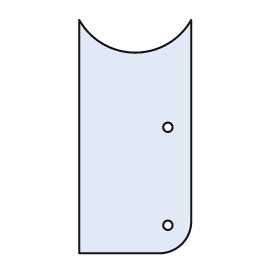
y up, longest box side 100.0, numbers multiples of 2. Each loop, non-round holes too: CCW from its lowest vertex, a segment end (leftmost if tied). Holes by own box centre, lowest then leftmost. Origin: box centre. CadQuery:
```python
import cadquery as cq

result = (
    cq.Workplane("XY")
    .moveTo(-24.0, -50.0)
    .lineTo(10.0, -50.0)
    .threePointArc((20.0, -46.0), (24.0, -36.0))
    .lineTo(24.0, 50.0)
    .threePointArc((0.0, 36.0), (-24.0, 50.0))
    .close()
    .moveTo(14.0, -38.0)
    .circle(2.0)
    .moveTo(14.0, 4.0)
    .circle(2.0)
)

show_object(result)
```